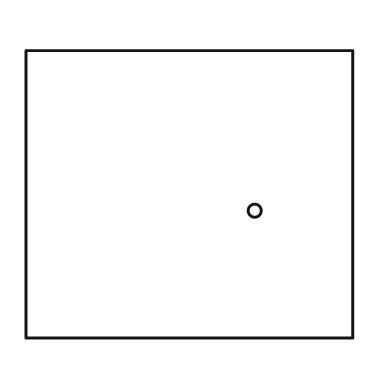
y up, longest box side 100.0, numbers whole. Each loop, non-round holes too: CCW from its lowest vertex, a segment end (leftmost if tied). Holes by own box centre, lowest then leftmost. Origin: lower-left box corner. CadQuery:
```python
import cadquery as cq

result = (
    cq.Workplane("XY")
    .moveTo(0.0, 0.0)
    .lineTo(100.0, 0.0)
    .lineTo(100.0, 88.0)
    .lineTo(0.0, 88.0)
    .close()
    .moveTo(70.0, 39.0)
    .circle(2.0)
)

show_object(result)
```